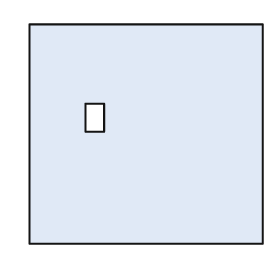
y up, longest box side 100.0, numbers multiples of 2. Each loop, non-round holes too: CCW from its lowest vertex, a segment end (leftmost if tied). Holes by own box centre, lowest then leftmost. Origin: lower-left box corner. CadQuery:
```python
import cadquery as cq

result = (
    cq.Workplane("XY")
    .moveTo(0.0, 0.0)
    .lineTo(100.0, 0.0)
    .lineTo(100.0, 94.0)
    .lineTo(0.0, 94.0)
    .close()
    .moveTo(24.0, 48.0)
    .lineTo(32.0, 48.0)
    .lineTo(32.0, 60.0)
    .lineTo(24.0, 60.0)
    .close()
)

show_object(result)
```